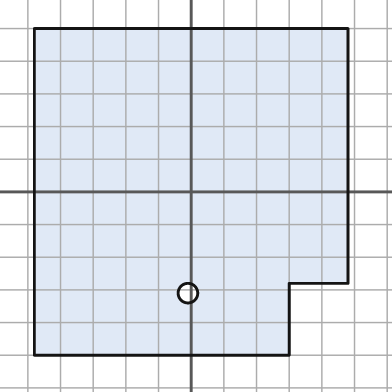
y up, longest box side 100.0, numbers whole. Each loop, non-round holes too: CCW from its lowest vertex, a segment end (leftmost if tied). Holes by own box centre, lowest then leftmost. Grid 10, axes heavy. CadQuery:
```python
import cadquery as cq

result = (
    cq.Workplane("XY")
    .moveTo(-48.0, -50.0)
    .lineTo(30.0, -50.0)
    .lineTo(30.0, -28.0)
    .lineTo(48.0, -28.0)
    .lineTo(48.0, 50.0)
    .lineTo(-48.0, 50.0)
    .close()
    .moveTo(-1.0, -31.0)
    .circle(3.0)
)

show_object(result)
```